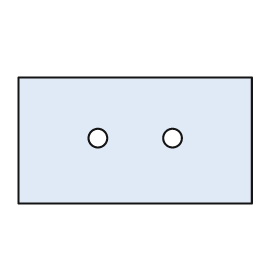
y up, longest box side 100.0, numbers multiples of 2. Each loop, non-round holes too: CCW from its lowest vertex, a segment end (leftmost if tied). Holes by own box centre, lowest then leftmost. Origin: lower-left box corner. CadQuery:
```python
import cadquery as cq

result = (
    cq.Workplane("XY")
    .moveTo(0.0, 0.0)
    .lineTo(100.0, 0.0)
    .lineTo(100.0, 54.0)
    .lineTo(0.0, 54.0)
    .close()
    .moveTo(34.0, 28.0)
    .circle(4.0)
    .moveTo(66.0, 28.0)
    .circle(4.0)
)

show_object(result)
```